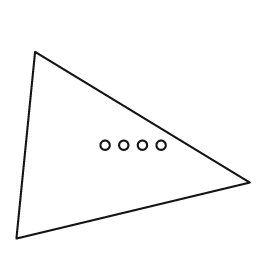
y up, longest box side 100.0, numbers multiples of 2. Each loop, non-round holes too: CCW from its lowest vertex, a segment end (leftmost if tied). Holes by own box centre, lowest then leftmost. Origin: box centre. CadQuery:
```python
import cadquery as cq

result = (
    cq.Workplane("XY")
    .moveTo(-50.0, -40.0)
    .lineTo(50.0, -16.0)
    .lineTo(-42.0, 40.0)
    .close()
    .moveTo(-12.0, 0.0)
    .circle(2.0)
    .moveTo(-4.0, 0.0)
    .circle(2.0)
    .moveTo(4.0, 0.0)
    .circle(2.0)
    .moveTo(12.0, 0.0)
    .circle(2.0)
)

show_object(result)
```